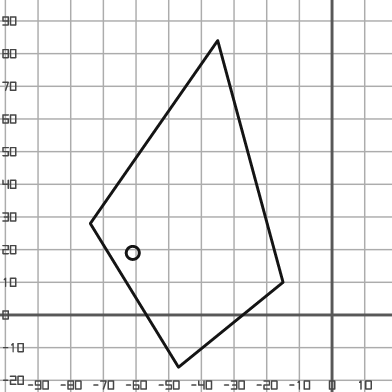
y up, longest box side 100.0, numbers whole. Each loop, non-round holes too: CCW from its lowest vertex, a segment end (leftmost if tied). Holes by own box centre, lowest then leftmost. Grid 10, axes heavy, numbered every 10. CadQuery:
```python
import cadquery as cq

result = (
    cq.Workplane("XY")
    .moveTo(-47.0, -16.0)
    .lineTo(-15.0, 10.0)
    .lineTo(-35.0, 84.0)
    .lineTo(-74.0, 28.0)
    .close()
    .moveTo(-61.0, 19.0)
    .circle(2.0)
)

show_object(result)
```